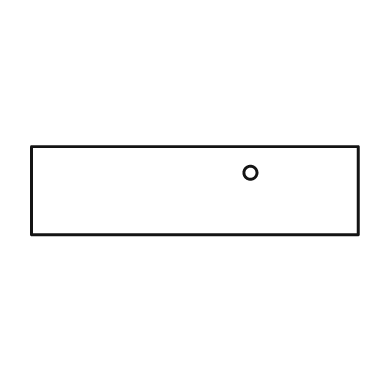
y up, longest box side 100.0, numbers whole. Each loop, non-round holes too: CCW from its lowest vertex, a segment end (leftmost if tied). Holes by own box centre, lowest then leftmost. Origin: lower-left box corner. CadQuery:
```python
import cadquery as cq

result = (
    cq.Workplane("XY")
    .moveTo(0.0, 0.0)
    .lineTo(100.0, 0.0)
    .lineTo(100.0, 27.0)
    .lineTo(0.0, 27.0)
    .close()
    .moveTo(67.0, 19.0)
    .circle(2.0)
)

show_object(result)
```